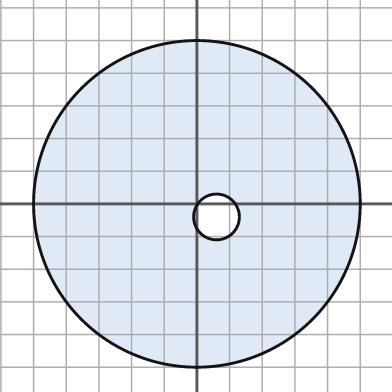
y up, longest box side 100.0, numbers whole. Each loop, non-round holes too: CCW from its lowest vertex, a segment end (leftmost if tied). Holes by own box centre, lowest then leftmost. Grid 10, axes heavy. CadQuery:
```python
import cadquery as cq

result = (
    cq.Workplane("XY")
    .moveTo(0.0, 0.0)
    .circle(50.0)
    .moveTo(6.0, -4.0)
    .circle(7.0)
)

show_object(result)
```